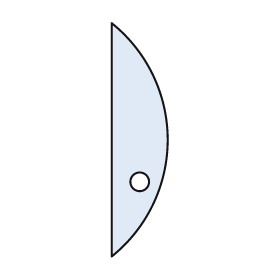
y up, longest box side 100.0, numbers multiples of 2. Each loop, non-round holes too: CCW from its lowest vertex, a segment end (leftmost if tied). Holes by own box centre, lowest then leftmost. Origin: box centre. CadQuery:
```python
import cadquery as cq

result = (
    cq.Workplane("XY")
    .moveTo(-12.0, -50.0)
    .threePointArc((12.0, 0.0), (-12.0, 50.0))
    .close()
    .moveTo(0.0, -18.0)
    .circle(4.0)
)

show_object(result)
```